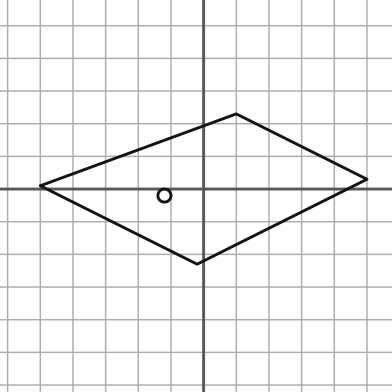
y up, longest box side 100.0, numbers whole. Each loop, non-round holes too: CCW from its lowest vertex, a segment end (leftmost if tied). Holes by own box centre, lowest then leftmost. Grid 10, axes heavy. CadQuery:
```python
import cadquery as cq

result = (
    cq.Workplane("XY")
    .moveTo(-2.0, -23.0)
    .lineTo(50.0, 3.0)
    .lineTo(10.0, 23.0)
    .lineTo(-50.0, 1.0)
    .close()
    .moveTo(-12.0, -2.0)
    .circle(2.0)
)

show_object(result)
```